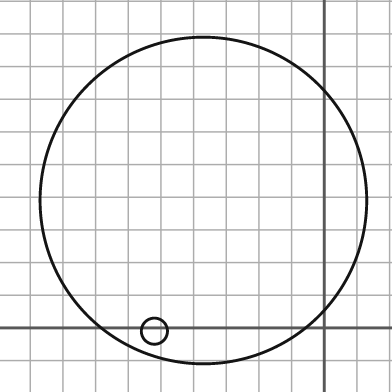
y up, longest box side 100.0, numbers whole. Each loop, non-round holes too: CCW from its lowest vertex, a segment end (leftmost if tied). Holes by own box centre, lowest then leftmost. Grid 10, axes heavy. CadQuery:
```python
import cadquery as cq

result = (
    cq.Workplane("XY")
    .moveTo(-37.0, 39.0)
    .circle(50.0)
    .moveTo(-52.0, -1.0)
    .circle(4.0)
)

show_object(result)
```